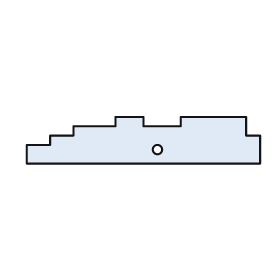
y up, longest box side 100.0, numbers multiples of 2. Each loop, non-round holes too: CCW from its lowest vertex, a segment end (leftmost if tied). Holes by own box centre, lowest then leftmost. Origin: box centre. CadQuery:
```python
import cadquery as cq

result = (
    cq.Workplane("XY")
    .moveTo(-50.0, -10.0)
    .lineTo(50.0, -10.0)
    .lineTo(50.0, 2.0)
    .lineTo(44.0, 2.0)
    .lineTo(44.0, 10.0)
    .lineTo(16.0, 10.0)
    .lineTo(16.0, 6.0)
    .lineTo(0.0, 6.0)
    .lineTo(0.0, 10.0)
    .lineTo(-12.0, 10.0)
    .lineTo(-12.0, 6.0)
    .lineTo(-30.0, 6.0)
    .lineTo(-30.0, 2.0)
    .lineTo(-40.0, 2.0)
    .lineTo(-40.0, -2.0)
    .lineTo(-50.0, -2.0)
    .close()
    .moveTo(6.0, -4.0)
    .circle(2.0)
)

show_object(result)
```